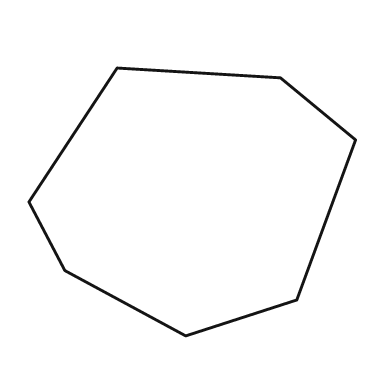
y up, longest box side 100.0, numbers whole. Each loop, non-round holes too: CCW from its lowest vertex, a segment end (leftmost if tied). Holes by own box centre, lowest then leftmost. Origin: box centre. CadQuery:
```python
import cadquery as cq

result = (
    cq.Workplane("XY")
    .moveTo(-2.0, -41.0)
    .lineTo(32.0, -30.0)
    .lineTo(50.0, 19.0)
    .lineTo(27.0, 38.0)
    .lineTo(-23.0, 41.0)
    .lineTo(-50.0, 0.0)
    .lineTo(-39.0, -21.0)
    .close()
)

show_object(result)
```